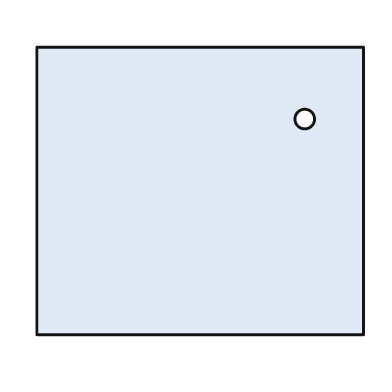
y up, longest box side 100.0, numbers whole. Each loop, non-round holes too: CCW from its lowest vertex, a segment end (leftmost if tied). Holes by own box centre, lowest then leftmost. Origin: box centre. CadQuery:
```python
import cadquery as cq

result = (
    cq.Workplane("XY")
    .moveTo(-50.0, -44.0)
    .lineTo(50.0, -44.0)
    .lineTo(50.0, 44.0)
    .lineTo(-50.0, 44.0)
    .close()
    .moveTo(32.0, 22.0)
    .circle(3.0)
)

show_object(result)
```